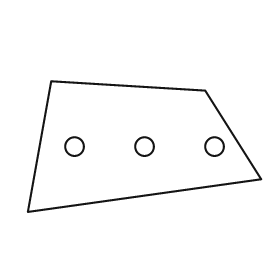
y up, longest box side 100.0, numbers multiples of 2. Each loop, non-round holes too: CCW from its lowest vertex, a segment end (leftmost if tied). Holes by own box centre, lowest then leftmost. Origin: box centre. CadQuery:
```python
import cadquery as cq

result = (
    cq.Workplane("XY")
    .moveTo(-50.0, -28.0)
    .lineTo(50.0, -14.0)
    .lineTo(26.0, 24.0)
    .lineTo(-40.0, 28.0)
    .close()
    .moveTo(-30.0, 0.0)
    .circle(4.0)
    .moveTo(0.0, 0.0)
    .circle(4.0)
    .moveTo(30.0, 0.0)
    .circle(4.0)
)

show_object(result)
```